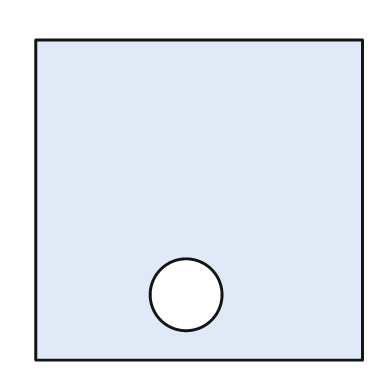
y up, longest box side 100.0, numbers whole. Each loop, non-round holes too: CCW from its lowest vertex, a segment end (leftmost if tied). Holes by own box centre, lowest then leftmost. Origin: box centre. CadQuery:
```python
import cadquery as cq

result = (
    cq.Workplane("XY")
    .moveTo(-50.0, -49.0)
    .lineTo(50.0, -49.0)
    .lineTo(50.0, 49.0)
    .lineTo(-50.0, 49.0)
    .close()
    .moveTo(-4.0, -29.0)
    .circle(11.0)
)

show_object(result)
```